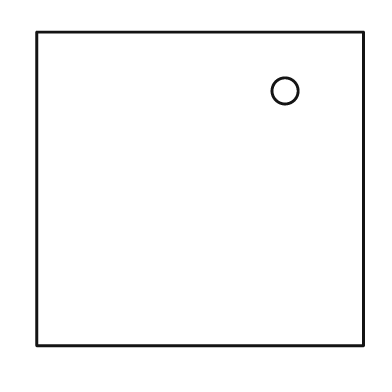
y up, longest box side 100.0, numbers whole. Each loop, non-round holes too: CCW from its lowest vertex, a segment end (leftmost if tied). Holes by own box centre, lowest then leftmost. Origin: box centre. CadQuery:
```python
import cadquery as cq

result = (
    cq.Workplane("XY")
    .moveTo(-50.0, -48.0)
    .lineTo(50.0, -48.0)
    .lineTo(50.0, 48.0)
    .lineTo(-50.0, 48.0)
    .close()
    .moveTo(26.0, 30.0)
    .circle(4.0)
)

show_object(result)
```